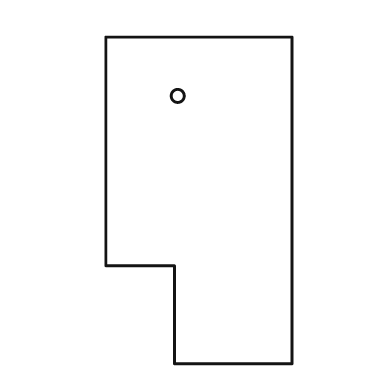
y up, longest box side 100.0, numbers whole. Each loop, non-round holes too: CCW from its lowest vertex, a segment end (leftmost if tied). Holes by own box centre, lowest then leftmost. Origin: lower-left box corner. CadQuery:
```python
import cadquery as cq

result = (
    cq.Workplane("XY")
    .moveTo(21.0, 0.0)
    .lineTo(57.0, 0.0)
    .lineTo(57.0, 100.0)
    .lineTo(0.0, 100.0)
    .lineTo(0.0, 30.0)
    .lineTo(21.0, 30.0)
    .close()
    .moveTo(22.0, 82.0)
    .circle(2.0)
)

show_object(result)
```